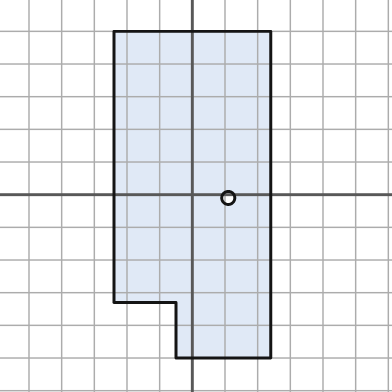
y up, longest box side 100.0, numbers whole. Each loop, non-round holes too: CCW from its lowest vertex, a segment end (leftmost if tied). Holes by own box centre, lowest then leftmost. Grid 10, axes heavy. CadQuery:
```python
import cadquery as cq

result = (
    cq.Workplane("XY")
    .moveTo(-5.0, -50.0)
    .lineTo(24.0, -50.0)
    .lineTo(24.0, 50.0)
    .lineTo(-24.0, 50.0)
    .lineTo(-24.0, -33.0)
    .lineTo(-5.0, -33.0)
    .close()
    .moveTo(11.0, -1.0)
    .circle(2.0)
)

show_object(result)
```